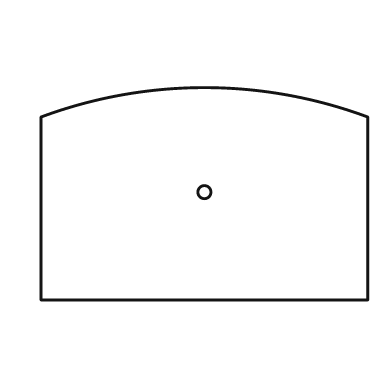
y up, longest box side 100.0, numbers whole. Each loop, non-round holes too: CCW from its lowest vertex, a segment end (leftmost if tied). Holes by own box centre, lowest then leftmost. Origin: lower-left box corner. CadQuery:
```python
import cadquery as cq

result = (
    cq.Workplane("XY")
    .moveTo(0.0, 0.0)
    .lineTo(100.0, 0.0)
    .lineTo(100.0, 56.0)
    .threePointArc((50.0, 65.0), (0.0, 56.0))
    .close()
    .moveTo(50.0, 33.0)
    .circle(2.0)
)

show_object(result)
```